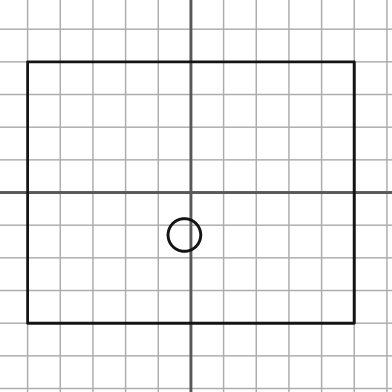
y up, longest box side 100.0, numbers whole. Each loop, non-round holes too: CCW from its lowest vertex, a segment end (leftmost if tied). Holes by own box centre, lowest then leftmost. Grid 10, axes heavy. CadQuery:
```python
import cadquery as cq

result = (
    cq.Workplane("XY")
    .moveTo(-50.0, -40.0)
    .lineTo(50.0, -40.0)
    .lineTo(50.0, 40.0)
    .lineTo(-50.0, 40.0)
    .close()
    .moveTo(-2.0, -13.0)
    .circle(5.0)
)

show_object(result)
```